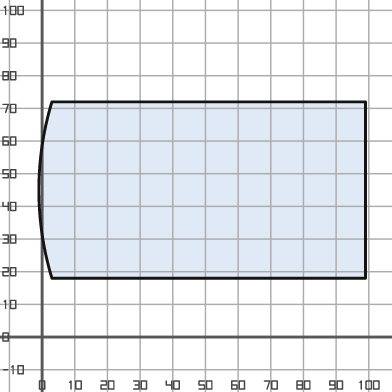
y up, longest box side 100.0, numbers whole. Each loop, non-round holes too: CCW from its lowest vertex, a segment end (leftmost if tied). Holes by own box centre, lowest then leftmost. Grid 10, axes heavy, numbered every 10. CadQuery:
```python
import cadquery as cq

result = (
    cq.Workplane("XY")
    .moveTo(3.0, 18.0)
    .lineTo(99.0, 18.0)
    .lineTo(99.0, 72.0)
    .lineTo(3.0, 72.0)
    .threePointArc((-1.0, 45.0), (3.0, 18.0))
    .close()
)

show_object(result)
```